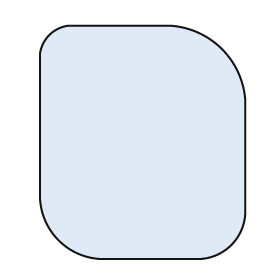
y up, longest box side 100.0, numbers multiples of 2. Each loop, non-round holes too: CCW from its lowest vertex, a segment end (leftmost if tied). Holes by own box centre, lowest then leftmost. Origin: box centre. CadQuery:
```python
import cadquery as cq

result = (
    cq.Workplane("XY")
    .moveTo(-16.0, -50.0)
    .lineTo(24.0, -50.0)
    .threePointArc((38.0, -44.0), (44.0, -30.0))
    .lineTo(44.0, 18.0)
    .threePointArc((34.0, 40.0), (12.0, 50.0))
    .lineTo(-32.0, 50.0)
    .threePointArc((-40.0, 46.0), (-44.0, 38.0))
    .lineTo(-44.0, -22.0)
    .threePointArc((-36.0, -42.0), (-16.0, -50.0))
    .close()
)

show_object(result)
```